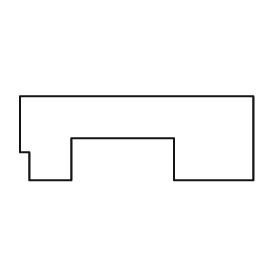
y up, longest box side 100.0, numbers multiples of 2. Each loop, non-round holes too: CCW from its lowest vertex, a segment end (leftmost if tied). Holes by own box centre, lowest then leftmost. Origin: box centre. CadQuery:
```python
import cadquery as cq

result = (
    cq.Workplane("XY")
    .moveTo(-46.0, -18.0)
    .lineTo(-28.0, -18.0)
    .lineTo(-28.0, 0.0)
    .lineTo(16.0, 0.0)
    .lineTo(16.0, -18.0)
    .lineTo(50.0, -18.0)
    .lineTo(50.0, 18.0)
    .lineTo(-50.0, 18.0)
    .lineTo(-50.0, -6.0)
    .lineTo(-46.0, -6.0)
    .close()
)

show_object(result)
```